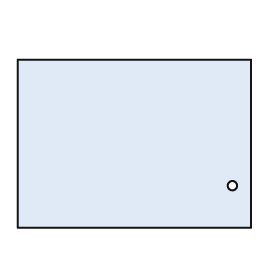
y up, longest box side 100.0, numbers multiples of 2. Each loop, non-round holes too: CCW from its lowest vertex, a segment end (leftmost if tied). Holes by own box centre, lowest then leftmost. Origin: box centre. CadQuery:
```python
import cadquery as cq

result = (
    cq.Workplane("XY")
    .moveTo(-50.0, -36.0)
    .lineTo(50.0, -36.0)
    .lineTo(50.0, 36.0)
    .lineTo(-50.0, 36.0)
    .close()
    .moveTo(42.0, -18.0)
    .circle(2.0)
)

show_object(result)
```